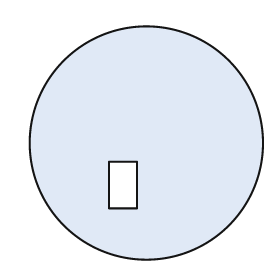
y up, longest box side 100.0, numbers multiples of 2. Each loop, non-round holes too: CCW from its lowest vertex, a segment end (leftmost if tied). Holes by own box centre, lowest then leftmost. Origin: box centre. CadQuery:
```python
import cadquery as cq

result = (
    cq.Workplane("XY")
    .moveTo(0.0, 0.0)
    .circle(50.0)
    .moveTo(-16.0, -28.0)
    .lineTo(-4.0, -28.0)
    .lineTo(-4.0, -8.0)
    .lineTo(-16.0, -8.0)
    .close()
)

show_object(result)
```